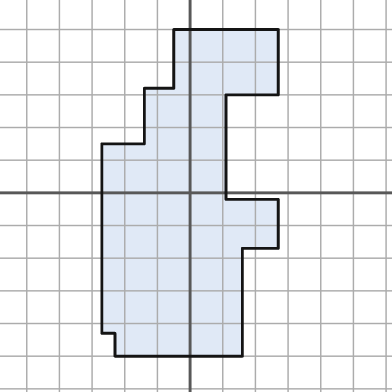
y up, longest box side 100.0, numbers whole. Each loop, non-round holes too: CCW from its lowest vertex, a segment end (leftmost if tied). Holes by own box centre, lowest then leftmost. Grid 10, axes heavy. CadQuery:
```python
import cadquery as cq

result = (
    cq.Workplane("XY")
    .moveTo(-23.0, -50.0)
    .lineTo(16.0, -50.0)
    .lineTo(16.0, -17.0)
    .lineTo(27.0, -17.0)
    .lineTo(27.0, -2.0)
    .lineTo(11.0, -2.0)
    .lineTo(11.0, 30.0)
    .lineTo(27.0, 30.0)
    .lineTo(27.0, 50.0)
    .lineTo(-5.0, 50.0)
    .lineTo(-5.0, 32.0)
    .lineTo(-14.0, 32.0)
    .lineTo(-14.0, 15.0)
    .lineTo(-27.0, 15.0)
    .lineTo(-27.0, -43.0)
    .lineTo(-23.0, -43.0)
    .close()
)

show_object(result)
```